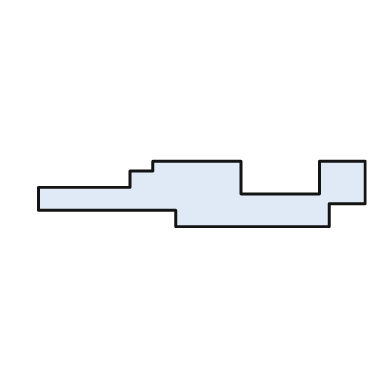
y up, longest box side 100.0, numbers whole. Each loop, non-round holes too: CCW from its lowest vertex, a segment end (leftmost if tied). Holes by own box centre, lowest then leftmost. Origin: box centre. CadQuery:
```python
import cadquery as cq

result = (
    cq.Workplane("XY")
    .moveTo(-8.0, -10.0)
    .lineTo(39.0, -10.0)
    .lineTo(39.0, -3.0)
    .lineTo(50.0, -3.0)
    .lineTo(50.0, 10.0)
    .lineTo(36.0, 10.0)
    .lineTo(36.0, 0.0)
    .lineTo(12.0, 0.0)
    .lineTo(12.0, 10.0)
    .lineTo(-15.0, 10.0)
    .lineTo(-15.0, 7.0)
    .lineTo(-22.0, 7.0)
    .lineTo(-22.0, 2.0)
    .lineTo(-50.0, 2.0)
    .lineTo(-50.0, -5.0)
    .lineTo(-8.0, -5.0)
    .close()
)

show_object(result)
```